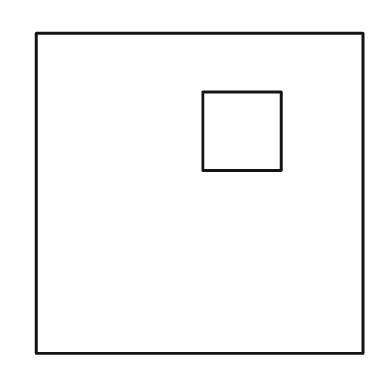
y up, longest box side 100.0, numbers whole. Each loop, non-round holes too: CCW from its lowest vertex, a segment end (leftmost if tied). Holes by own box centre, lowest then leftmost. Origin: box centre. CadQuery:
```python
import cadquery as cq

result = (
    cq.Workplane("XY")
    .moveTo(-50.0, -49.0)
    .lineTo(50.0, -49.0)
    .lineTo(50.0, 49.0)
    .lineTo(-50.0, 49.0)
    .close()
    .moveTo(1.0, 7.0)
    .lineTo(25.0, 7.0)
    .lineTo(25.0, 31.0)
    .lineTo(1.0, 31.0)
    .close()
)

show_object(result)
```